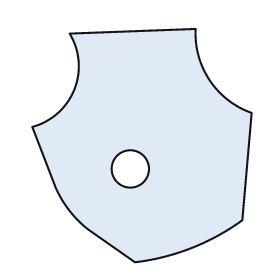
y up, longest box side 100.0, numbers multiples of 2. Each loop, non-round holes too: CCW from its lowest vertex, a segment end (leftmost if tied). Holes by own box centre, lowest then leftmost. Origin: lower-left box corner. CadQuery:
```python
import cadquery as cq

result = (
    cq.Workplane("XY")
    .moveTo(44.0, 0.0)
    .threePointArc((68.0, 6.0), (90.0, 18.0))
    .lineTo(94.0, 64.0)
    .threePointArc((76.0, 78.0), (70.0, 100.0))
    .lineTo(16.0, 98.0)
    .threePointArc((18.0, 74.0), (0.0, 58.0))
    .lineTo(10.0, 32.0)
    .threePointArc((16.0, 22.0), (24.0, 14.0))
    .close()
    .moveTo(42.0, 40.0)
    .circle(8.0)
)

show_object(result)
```